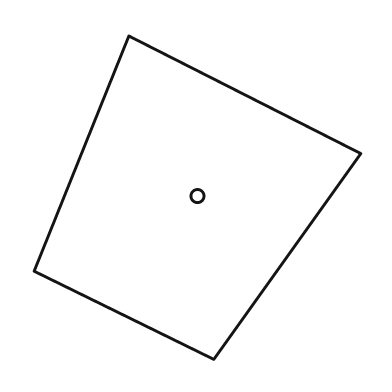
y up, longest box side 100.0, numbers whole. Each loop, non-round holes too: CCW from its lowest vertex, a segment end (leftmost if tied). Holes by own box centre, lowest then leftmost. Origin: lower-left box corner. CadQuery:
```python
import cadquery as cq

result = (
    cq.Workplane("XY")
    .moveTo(55.0, 0.0)
    .lineTo(100.0, 63.0)
    .lineTo(29.0, 99.0)
    .lineTo(0.0, 27.0)
    .close()
    .moveTo(50.0, 50.0)
    .circle(2.0)
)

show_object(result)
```